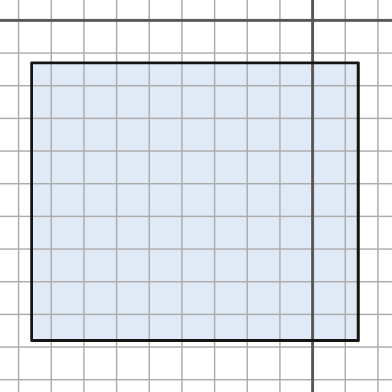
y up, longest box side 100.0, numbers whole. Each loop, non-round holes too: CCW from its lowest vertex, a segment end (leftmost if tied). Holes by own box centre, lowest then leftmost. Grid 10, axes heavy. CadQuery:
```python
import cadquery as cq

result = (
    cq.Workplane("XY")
    .moveTo(-86.0, -98.0)
    .lineTo(14.0, -98.0)
    .lineTo(14.0, -13.0)
    .lineTo(-86.0, -13.0)
    .close()
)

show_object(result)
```